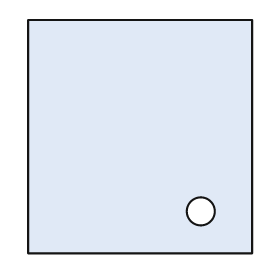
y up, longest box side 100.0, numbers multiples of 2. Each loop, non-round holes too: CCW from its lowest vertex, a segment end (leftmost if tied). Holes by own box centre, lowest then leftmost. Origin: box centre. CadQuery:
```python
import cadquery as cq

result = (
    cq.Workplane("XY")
    .moveTo(-48.0, -50.0)
    .lineTo(48.0, -50.0)
    .lineTo(48.0, 50.0)
    .lineTo(-48.0, 50.0)
    .close()
    .moveTo(26.0, -32.0)
    .circle(6.0)
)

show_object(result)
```